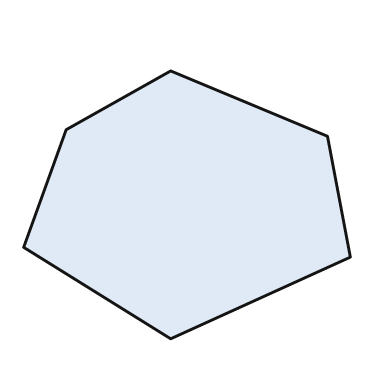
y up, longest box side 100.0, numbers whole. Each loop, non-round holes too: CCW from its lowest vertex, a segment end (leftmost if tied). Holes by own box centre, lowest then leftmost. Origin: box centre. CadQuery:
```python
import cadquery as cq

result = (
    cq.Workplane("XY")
    .moveTo(-5.0, -41.0)
    .lineTo(50.0, -16.0)
    .lineTo(43.0, 21.0)
    .lineTo(-5.0, 41.0)
    .lineTo(-37.0, 23.0)
    .lineTo(-50.0, -13.0)
    .close()
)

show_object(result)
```